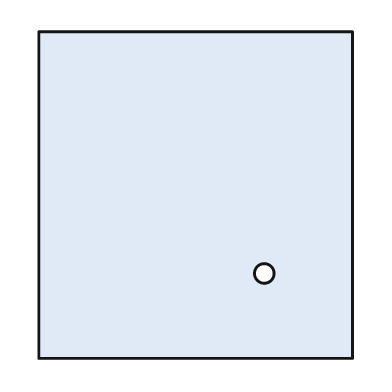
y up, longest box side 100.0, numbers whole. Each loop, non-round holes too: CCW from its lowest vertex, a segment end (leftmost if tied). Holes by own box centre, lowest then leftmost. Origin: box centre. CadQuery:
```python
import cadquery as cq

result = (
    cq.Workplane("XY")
    .moveTo(-48.0, -50.0)
    .lineTo(48.0, -50.0)
    .lineTo(48.0, 50.0)
    .lineTo(-48.0, 50.0)
    .close()
    .moveTo(21.0, -24.0)
    .circle(3.0)
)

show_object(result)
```